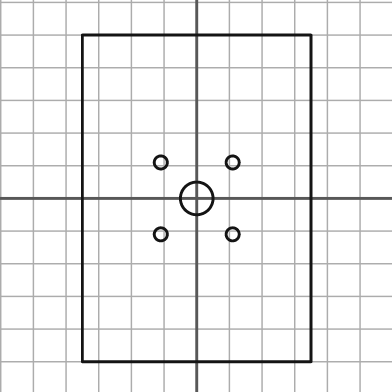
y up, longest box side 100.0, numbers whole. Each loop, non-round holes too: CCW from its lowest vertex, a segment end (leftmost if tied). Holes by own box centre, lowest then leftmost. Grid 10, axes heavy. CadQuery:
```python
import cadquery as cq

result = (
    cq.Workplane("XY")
    .moveTo(-35.0, -50.0)
    .lineTo(35.0, -50.0)
    .lineTo(35.0, 50.0)
    .lineTo(-35.0, 50.0)
    .close()
    .moveTo(-11.0, -11.0)
    .circle(2.0)
    .moveTo(11.0, -11.0)
    .circle(2.0)
    .moveTo(0.0, 0.0)
    .circle(5.0)
    .moveTo(-11.0, 11.0)
    .circle(2.0)
    .moveTo(11.0, 11.0)
    .circle(2.0)
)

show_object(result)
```